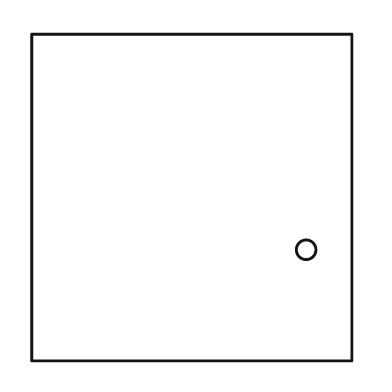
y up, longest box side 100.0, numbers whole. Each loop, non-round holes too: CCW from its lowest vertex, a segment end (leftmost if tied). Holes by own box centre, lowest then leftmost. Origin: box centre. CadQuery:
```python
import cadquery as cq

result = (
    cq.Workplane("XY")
    .moveTo(-49.0, -50.0)
    .lineTo(49.0, -50.0)
    .lineTo(49.0, 50.0)
    .lineTo(-49.0, 50.0)
    .close()
    .moveTo(35.0, -16.0)
    .circle(3.0)
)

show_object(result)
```